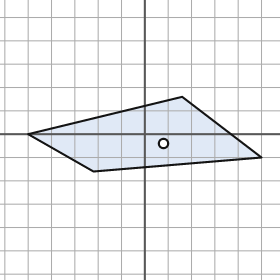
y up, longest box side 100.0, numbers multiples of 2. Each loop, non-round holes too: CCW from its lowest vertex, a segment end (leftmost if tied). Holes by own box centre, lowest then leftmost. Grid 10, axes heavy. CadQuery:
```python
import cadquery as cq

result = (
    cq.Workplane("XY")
    .moveTo(-22.0, -16.0)
    .lineTo(50.0, -10.0)
    .lineTo(16.0, 16.0)
    .lineTo(-50.0, 0.0)
    .close()
    .moveTo(8.0, -4.0)
    .circle(2.0)
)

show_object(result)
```